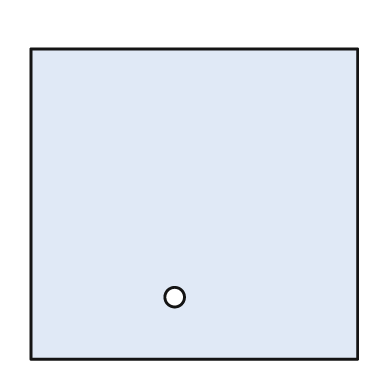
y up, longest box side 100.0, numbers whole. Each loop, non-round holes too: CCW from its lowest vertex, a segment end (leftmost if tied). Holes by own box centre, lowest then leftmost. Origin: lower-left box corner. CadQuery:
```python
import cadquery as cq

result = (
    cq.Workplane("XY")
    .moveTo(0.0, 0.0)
    .lineTo(100.0, 0.0)
    .lineTo(100.0, 95.0)
    .lineTo(0.0, 95.0)
    .close()
    .moveTo(44.0, 19.0)
    .circle(3.0)
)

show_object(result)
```